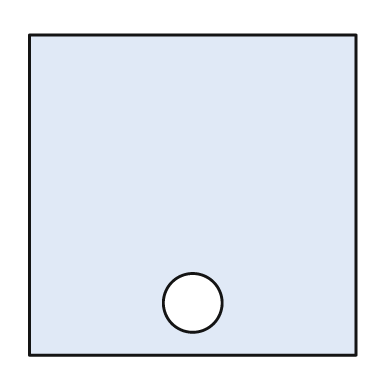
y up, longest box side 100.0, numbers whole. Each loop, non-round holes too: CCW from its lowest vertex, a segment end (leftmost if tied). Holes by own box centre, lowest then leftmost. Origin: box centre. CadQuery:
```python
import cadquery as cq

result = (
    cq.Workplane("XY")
    .moveTo(-50.0, -49.0)
    .lineTo(50.0, -49.0)
    .lineTo(50.0, 49.0)
    .lineTo(-50.0, 49.0)
    .close()
    .moveTo(0.0, -33.0)
    .circle(9.0)
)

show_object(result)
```